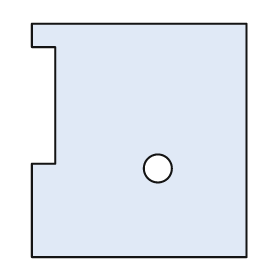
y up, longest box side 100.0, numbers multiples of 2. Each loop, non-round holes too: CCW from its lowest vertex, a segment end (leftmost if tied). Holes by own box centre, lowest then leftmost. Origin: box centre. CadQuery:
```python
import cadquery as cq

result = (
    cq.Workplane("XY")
    .moveTo(-46.0, -50.0)
    .lineTo(46.0, -50.0)
    .lineTo(46.0, 50.0)
    .lineTo(-46.0, 50.0)
    .lineTo(-46.0, 40.0)
    .lineTo(-36.0, 40.0)
    .lineTo(-36.0, -10.0)
    .lineTo(-46.0, -10.0)
    .close()
    .moveTo(8.0, -12.0)
    .circle(6.0)
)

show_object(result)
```